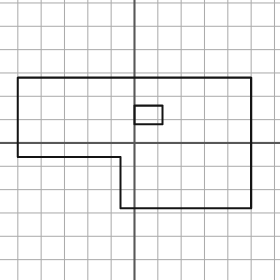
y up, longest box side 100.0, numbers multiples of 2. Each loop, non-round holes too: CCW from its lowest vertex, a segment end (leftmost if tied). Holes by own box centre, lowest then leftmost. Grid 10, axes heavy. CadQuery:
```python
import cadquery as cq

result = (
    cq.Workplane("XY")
    .moveTo(-6.0, -28.0)
    .lineTo(50.0, -28.0)
    .lineTo(50.0, 28.0)
    .lineTo(-50.0, 28.0)
    .lineTo(-50.0, -6.0)
    .lineTo(-6.0, -6.0)
    .close()
    .moveTo(0.0, 8.0)
    .lineTo(12.0, 8.0)
    .lineTo(12.0, 16.0)
    .lineTo(0.0, 16.0)
    .close()
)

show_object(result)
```